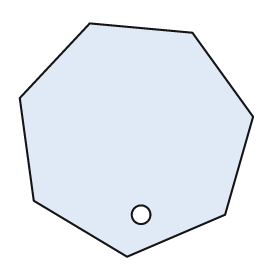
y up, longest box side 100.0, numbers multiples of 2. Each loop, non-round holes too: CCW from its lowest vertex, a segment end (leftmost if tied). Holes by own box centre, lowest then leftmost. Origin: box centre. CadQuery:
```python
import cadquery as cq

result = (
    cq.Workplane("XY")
    .moveTo(-4.0, -50.0)
    .lineTo(38.0, -32.0)
    .lineTo(50.0, 10.0)
    .lineTo(24.0, 46.0)
    .lineTo(-20.0, 50.0)
    .lineTo(-50.0, 18.0)
    .lineTo(-44.0, -26.0)
    .close()
    .moveTo(2.0, -32.0)
    .circle(4.0)
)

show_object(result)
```